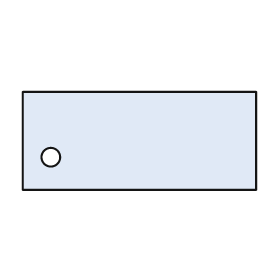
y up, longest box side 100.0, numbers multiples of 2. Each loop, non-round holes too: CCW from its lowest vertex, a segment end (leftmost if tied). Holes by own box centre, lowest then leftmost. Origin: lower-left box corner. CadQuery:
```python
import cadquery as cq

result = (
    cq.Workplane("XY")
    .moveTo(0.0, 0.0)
    .lineTo(100.0, 0.0)
    .lineTo(100.0, 42.0)
    .lineTo(0.0, 42.0)
    .close()
    .moveTo(12.0, 14.0)
    .circle(4.0)
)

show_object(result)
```